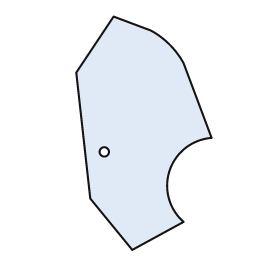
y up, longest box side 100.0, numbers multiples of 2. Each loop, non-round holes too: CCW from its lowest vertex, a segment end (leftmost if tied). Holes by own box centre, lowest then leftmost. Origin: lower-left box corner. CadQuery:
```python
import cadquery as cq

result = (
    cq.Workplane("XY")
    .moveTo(24.0, 0.0)
    .lineTo(46.0, 12.0)
    .threePointArc((40.0, 34.0), (58.0, 48.0))
    .lineTo(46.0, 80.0)
    .threePointArc((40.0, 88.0), (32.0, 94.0))
    .lineTo(16.0, 100.0)
    .lineTo(0.0, 76.0)
    .lineTo(6.0, 22.0)
    .close()
    .moveTo(12.0, 42.0)
    .circle(2.0)
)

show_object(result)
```